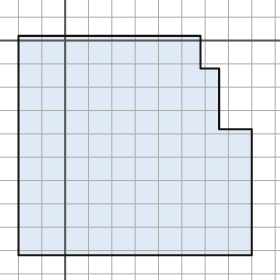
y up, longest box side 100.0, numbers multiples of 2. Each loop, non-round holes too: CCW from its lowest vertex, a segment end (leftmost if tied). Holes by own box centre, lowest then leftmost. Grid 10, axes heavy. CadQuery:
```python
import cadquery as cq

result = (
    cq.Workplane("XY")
    .moveTo(-20.0, -92.0)
    .lineTo(80.0, -92.0)
    .lineTo(80.0, -38.0)
    .lineTo(66.0, -38.0)
    .lineTo(66.0, -12.0)
    .lineTo(58.0, -12.0)
    .lineTo(58.0, 2.0)
    .lineTo(-20.0, 2.0)
    .close()
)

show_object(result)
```